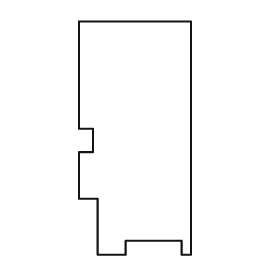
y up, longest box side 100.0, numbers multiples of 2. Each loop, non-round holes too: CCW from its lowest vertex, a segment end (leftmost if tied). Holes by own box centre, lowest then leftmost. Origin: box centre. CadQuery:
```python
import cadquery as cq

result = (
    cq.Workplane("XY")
    .moveTo(-16.0, -50.0)
    .lineTo(-4.0, -50.0)
    .lineTo(-4.0, -44.0)
    .lineTo(20.0, -44.0)
    .lineTo(20.0, -50.0)
    .lineTo(24.0, -50.0)
    .lineTo(24.0, 50.0)
    .lineTo(-24.0, 50.0)
    .lineTo(-24.0, 4.0)
    .lineTo(-18.0, 4.0)
    .lineTo(-18.0, -6.0)
    .lineTo(-24.0, -6.0)
    .lineTo(-24.0, -26.0)
    .lineTo(-16.0, -26.0)
    .close()
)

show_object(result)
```